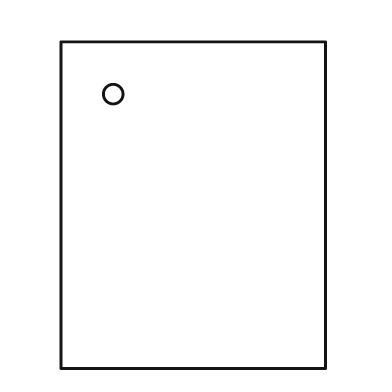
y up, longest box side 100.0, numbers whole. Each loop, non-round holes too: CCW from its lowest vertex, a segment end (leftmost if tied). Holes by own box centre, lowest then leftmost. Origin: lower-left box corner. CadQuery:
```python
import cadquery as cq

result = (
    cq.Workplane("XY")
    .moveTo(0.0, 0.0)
    .lineTo(81.0, 0.0)
    .lineTo(81.0, 100.0)
    .lineTo(0.0, 100.0)
    .close()
    .moveTo(16.0, 84.0)
    .circle(3.0)
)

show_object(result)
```